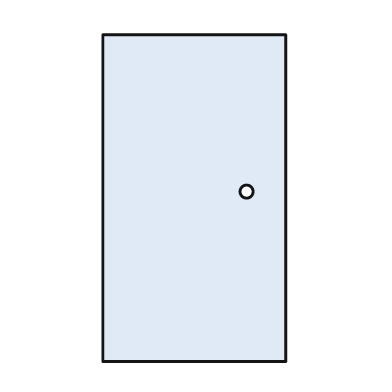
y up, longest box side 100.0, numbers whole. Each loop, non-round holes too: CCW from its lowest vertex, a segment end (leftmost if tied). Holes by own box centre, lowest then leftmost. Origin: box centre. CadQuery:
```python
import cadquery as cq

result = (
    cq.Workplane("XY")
    .moveTo(-28.0, -50.0)
    .lineTo(28.0, -50.0)
    .lineTo(28.0, 50.0)
    .lineTo(-28.0, 50.0)
    .close()
    .moveTo(16.0, 2.0)
    .circle(2.0)
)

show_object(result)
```